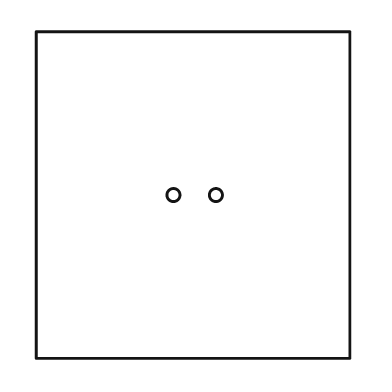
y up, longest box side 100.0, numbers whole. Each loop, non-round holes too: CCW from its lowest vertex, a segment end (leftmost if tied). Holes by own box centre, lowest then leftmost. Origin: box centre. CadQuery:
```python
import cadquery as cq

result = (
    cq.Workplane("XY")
    .moveTo(-48.0, -50.0)
    .lineTo(48.0, -50.0)
    .lineTo(48.0, 50.0)
    .lineTo(-48.0, 50.0)
    .close()
    .moveTo(-6.0, 0.0)
    .circle(2.0)
    .moveTo(7.0, 0.0)
    .circle(2.0)
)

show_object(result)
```